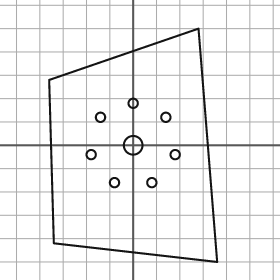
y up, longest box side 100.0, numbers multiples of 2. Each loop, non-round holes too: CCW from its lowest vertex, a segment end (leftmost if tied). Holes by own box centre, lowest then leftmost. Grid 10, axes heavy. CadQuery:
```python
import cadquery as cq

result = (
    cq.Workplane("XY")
    .moveTo(36.0, -50.0)
    .lineTo(28.0, 50.0)
    .lineTo(-36.0, 28.0)
    .lineTo(-34.0, -42.0)
    .close()
    .moveTo(-8.0, -16.0)
    .circle(2.0)
    .moveTo(8.0, -16.0)
    .circle(2.0)
    .moveTo(-18.0, -4.0)
    .circle(2.0)
    .moveTo(18.0, -4.0)
    .circle(2.0)
    .moveTo(0.0, 0.0)
    .circle(4.0)
    .moveTo(-14.0, 12.0)
    .circle(2.0)
    .moveTo(14.0, 12.0)
    .circle(2.0)
    .moveTo(0.0, 18.0)
    .circle(2.0)
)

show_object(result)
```